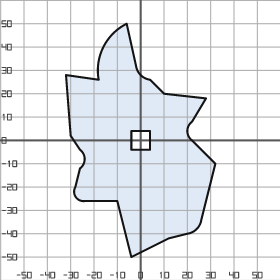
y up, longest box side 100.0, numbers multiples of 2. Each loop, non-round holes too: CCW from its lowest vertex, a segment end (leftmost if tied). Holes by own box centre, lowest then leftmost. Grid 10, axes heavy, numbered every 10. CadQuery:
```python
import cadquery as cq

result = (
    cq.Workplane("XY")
    .moveTo(-4.0, -50.0)
    .lineTo(12.0, -42.0)
    .lineTo(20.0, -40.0)
    .threePointArc((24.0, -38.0), (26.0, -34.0))
    .lineTo(32.0, -10.0)
    .lineTo(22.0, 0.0)
    .threePointArc((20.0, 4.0), (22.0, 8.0))
    .lineTo(28.0, 18.0)
    .lineTo(10.0, 20.0)
    .lineTo(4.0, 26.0)
    .threePointArc((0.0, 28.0), (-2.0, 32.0))
    .lineTo(-6.0, 50.0)
    .threePointArc((-16.0, 40.0), (-18.0, 26.0))
    .lineTo(-32.0, 28.0)
    .lineTo(-30.0, 2.0)
    .lineTo(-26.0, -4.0)
    .threePointArc((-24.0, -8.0), (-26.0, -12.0))
    .lineTo(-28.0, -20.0)
    .threePointArc((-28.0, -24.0), (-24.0, -26.0))
    .lineTo(-10.0, -26.0)
    .close()
    .moveTo(-4.0, -4.0)
    .lineTo(4.0, -4.0)
    .lineTo(4.0, 4.0)
    .lineTo(-4.0, 4.0)
    .close()
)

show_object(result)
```